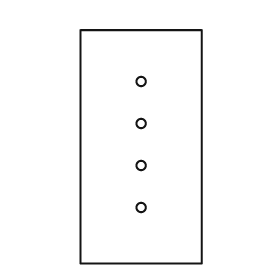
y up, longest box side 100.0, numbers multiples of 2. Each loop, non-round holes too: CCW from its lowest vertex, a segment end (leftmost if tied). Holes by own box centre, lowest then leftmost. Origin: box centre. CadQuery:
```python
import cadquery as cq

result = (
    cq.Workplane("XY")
    .moveTo(-26.0, -50.0)
    .lineTo(26.0, -50.0)
    .lineTo(26.0, 50.0)
    .lineTo(-26.0, 50.0)
    .close()
    .moveTo(0.0, -26.0)
    .circle(2.0)
    .moveTo(0.0, -8.0)
    .circle(2.0)
    .moveTo(0.0, 10.0)
    .circle(2.0)
    .moveTo(0.0, 28.0)
    .circle(2.0)
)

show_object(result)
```